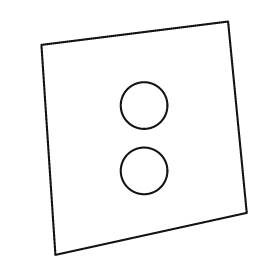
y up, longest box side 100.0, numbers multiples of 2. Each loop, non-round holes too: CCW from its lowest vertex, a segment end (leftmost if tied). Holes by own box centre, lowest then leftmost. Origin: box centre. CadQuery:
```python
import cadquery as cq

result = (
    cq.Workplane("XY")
    .moveTo(-38.0, -50.0)
    .lineTo(44.0, -32.0)
    .lineTo(36.0, 50.0)
    .lineTo(-44.0, 40.0)
    .close()
    .moveTo(0.0, -14.0)
    .circle(10.0)
    .moveTo(0.0, 14.0)
    .circle(10.0)
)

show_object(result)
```